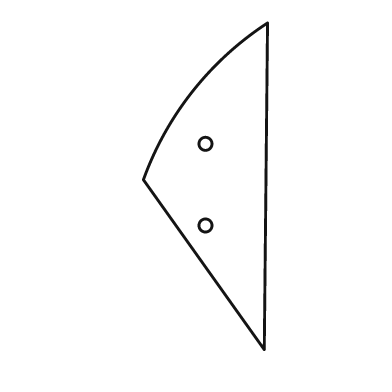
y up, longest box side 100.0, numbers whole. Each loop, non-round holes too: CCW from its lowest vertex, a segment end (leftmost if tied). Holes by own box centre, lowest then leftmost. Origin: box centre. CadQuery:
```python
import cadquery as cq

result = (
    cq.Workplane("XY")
    .moveTo(18.0, -50.0)
    .lineTo(19.0, 50.0)
    .threePointArc((-4.0, 29.0), (-19.0, 2.0))
    .close()
    .moveTo(0.0, -12.0)
    .circle(2.0)
    .moveTo(0.0, 13.0)
    .circle(2.0)
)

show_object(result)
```